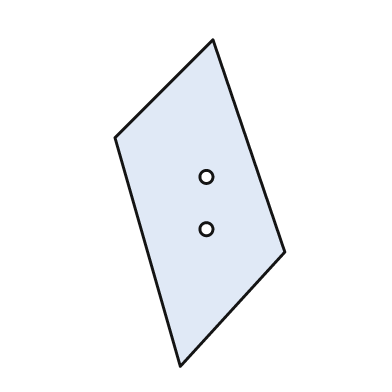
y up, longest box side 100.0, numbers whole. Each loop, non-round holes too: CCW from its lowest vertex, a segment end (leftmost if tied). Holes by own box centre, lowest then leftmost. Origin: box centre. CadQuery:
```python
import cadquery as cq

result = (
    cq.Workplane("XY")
    .moveTo(-6.0, -50.0)
    .lineTo(26.0, -15.0)
    .lineTo(4.0, 50.0)
    .lineTo(-26.0, 20.0)
    .close()
    .moveTo(2.0, -8.0)
    .circle(2.0)
    .moveTo(2.0, 8.0)
    .circle(2.0)
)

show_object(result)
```